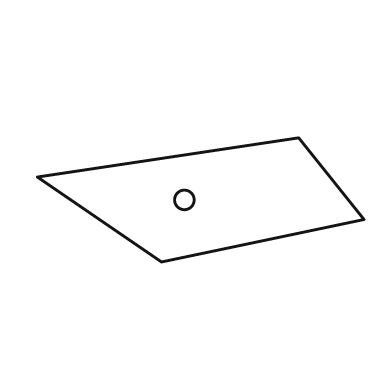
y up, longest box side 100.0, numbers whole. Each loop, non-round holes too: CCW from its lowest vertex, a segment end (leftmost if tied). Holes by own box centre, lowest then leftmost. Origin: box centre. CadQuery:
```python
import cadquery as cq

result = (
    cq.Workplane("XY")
    .moveTo(-12.0, -19.0)
    .lineTo(50.0, -6.0)
    .lineTo(30.0, 19.0)
    .lineTo(-50.0, 7.0)
    .close()
    .moveTo(-5.0, 0.0)
    .circle(3.0)
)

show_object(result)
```